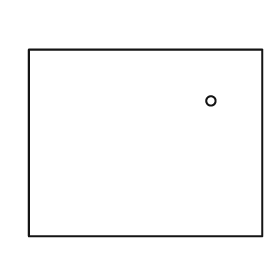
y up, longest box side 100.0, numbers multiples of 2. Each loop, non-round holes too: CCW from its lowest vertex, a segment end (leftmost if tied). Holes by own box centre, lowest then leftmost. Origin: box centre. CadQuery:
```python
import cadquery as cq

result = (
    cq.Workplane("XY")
    .moveTo(-50.0, -40.0)
    .lineTo(50.0, -40.0)
    .lineTo(50.0, 40.0)
    .lineTo(-50.0, 40.0)
    .close()
    .moveTo(28.0, 18.0)
    .circle(2.0)
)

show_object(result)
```